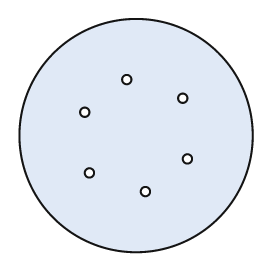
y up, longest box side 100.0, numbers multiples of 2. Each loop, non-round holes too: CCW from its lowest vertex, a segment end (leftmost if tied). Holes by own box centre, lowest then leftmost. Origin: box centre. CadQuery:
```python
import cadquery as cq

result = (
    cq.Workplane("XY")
    .moveTo(0.0, 0.0)
    .circle(50.0)
    .moveTo(4.0, -24.0)
    .circle(2.0)
    .moveTo(-20.0, -16.0)
    .circle(2.0)
    .moveTo(22.0, -10.0)
    .circle(2.0)
    .moveTo(-22.0, 10.0)
    .circle(2.0)
    .moveTo(20.0, 16.0)
    .circle(2.0)
    .moveTo(-4.0, 24.0)
    .circle(2.0)
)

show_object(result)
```